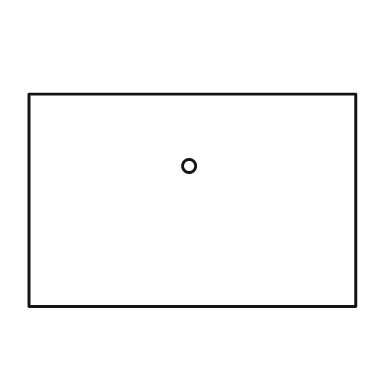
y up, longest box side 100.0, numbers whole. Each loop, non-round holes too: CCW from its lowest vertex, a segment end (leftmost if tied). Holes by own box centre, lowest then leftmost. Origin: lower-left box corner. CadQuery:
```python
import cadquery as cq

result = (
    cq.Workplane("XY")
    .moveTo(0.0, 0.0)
    .lineTo(100.0, 0.0)
    .lineTo(100.0, 65.0)
    .lineTo(0.0, 65.0)
    .close()
    .moveTo(49.0, 43.0)
    .circle(2.0)
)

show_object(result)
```